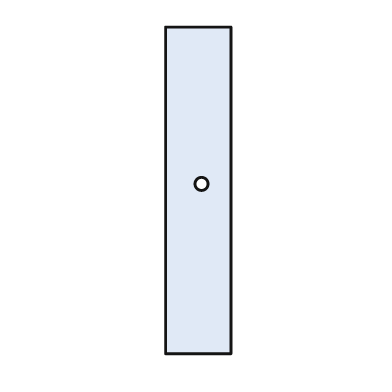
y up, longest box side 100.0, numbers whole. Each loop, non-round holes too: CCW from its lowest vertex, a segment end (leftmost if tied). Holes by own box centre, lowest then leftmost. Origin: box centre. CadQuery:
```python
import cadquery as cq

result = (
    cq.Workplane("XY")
    .moveTo(-10.0, -50.0)
    .lineTo(10.0, -50.0)
    .lineTo(10.0, 50.0)
    .lineTo(-10.0, 50.0)
    .close()
    .moveTo(1.0, 2.0)
    .circle(2.0)
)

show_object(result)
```